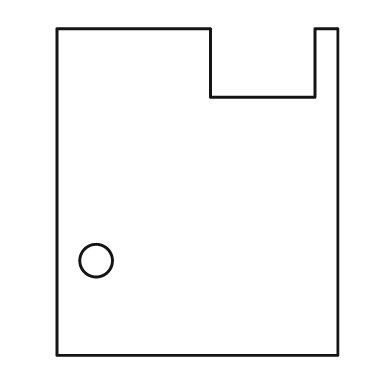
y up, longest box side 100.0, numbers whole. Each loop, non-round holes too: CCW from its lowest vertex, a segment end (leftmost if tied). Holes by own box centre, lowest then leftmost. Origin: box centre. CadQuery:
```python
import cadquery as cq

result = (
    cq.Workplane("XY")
    .moveTo(-43.0, -50.0)
    .lineTo(43.0, -50.0)
    .lineTo(43.0, 50.0)
    .lineTo(36.0, 50.0)
    .lineTo(36.0, 29.0)
    .lineTo(4.0, 29.0)
    .lineTo(4.0, 50.0)
    .lineTo(-43.0, 50.0)
    .close()
    .moveTo(-31.0, -21.0)
    .circle(5.0)
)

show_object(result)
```